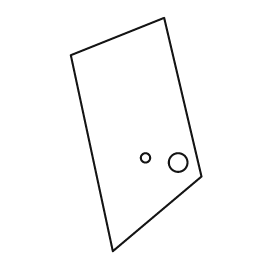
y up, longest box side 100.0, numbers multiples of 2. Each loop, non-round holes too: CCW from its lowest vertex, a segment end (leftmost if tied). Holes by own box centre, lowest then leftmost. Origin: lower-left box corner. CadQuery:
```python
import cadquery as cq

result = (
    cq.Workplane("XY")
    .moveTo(18.0, 0.0)
    .lineTo(56.0, 32.0)
    .lineTo(40.0, 100.0)
    .lineTo(0.0, 84.0)
    .close()
    .moveTo(46.0, 38.0)
    .circle(4.0)
    .moveTo(32.0, 40.0)
    .circle(2.0)
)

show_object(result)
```